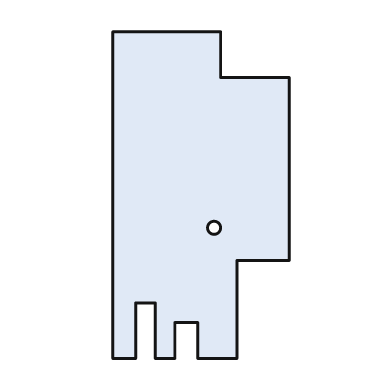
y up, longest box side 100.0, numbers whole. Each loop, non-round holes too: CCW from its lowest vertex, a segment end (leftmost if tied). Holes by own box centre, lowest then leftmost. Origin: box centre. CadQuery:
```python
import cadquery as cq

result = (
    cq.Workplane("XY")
    .moveTo(-27.0, -50.0)
    .lineTo(-20.0, -50.0)
    .lineTo(-20.0, -33.0)
    .lineTo(-14.0, -33.0)
    .lineTo(-14.0, -50.0)
    .lineTo(-8.0, -50.0)
    .lineTo(-8.0, -39.0)
    .lineTo(-1.0, -39.0)
    .lineTo(-1.0, -50.0)
    .lineTo(11.0, -50.0)
    .lineTo(11.0, -20.0)
    .lineTo(27.0, -20.0)
    .lineTo(27.0, 36.0)
    .lineTo(6.0, 36.0)
    .lineTo(6.0, 50.0)
    .lineTo(-27.0, 50.0)
    .close()
    .moveTo(4.0, -10.0)
    .circle(2.0)
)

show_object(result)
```